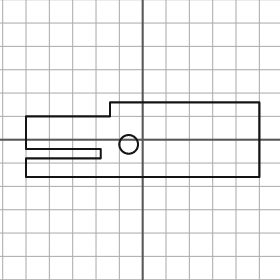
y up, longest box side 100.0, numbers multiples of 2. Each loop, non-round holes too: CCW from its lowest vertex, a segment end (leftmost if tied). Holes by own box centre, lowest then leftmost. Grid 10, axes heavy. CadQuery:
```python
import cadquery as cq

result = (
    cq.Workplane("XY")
    .moveTo(-50.0, -16.0)
    .lineTo(50.0, -16.0)
    .lineTo(50.0, 16.0)
    .lineTo(-14.0, 16.0)
    .lineTo(-14.0, 10.0)
    .lineTo(-50.0, 10.0)
    .lineTo(-50.0, -4.0)
    .lineTo(-18.0, -4.0)
    .lineTo(-18.0, -8.0)
    .lineTo(-50.0, -8.0)
    .close()
    .moveTo(-6.0, -2.0)
    .circle(4.0)
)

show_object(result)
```